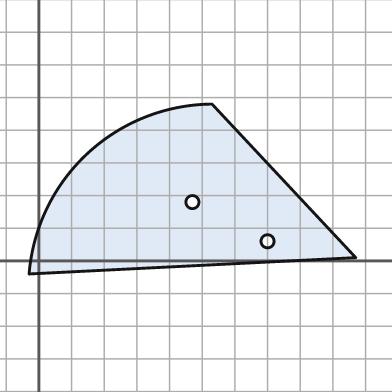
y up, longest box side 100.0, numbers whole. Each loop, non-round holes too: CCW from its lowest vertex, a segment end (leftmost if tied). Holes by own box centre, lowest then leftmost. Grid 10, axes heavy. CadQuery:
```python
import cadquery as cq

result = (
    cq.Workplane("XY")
    .moveTo(-3.0, -4.0)
    .lineTo(97.0, 1.0)
    .lineTo(53.0, 48.0)
    .threePointArc((15.0, 33.0), (-3.0, -4.0))
    .close()
    .moveTo(70.0, 6.0)
    .circle(2.0)
    .moveTo(47.0, 18.0)
    .circle(2.0)
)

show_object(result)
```